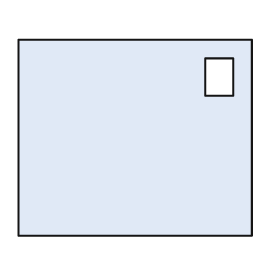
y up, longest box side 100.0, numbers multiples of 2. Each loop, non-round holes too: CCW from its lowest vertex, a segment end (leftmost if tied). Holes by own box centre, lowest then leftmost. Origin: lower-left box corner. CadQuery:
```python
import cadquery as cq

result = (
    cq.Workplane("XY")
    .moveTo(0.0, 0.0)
    .lineTo(100.0, 0.0)
    .lineTo(100.0, 84.0)
    .lineTo(0.0, 84.0)
    .close()
    .moveTo(80.0, 60.0)
    .lineTo(92.0, 60.0)
    .lineTo(92.0, 76.0)
    .lineTo(80.0, 76.0)
    .close()
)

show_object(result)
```